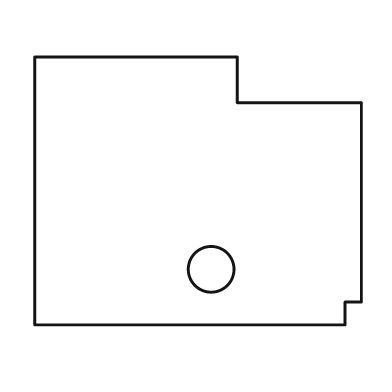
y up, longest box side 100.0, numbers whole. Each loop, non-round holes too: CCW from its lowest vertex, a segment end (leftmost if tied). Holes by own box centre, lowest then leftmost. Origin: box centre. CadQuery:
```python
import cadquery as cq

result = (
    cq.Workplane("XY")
    .moveTo(-50.0, -41.0)
    .lineTo(45.0, -41.0)
    .lineTo(45.0, -34.0)
    .lineTo(50.0, -34.0)
    .lineTo(50.0, 27.0)
    .lineTo(12.0, 27.0)
    .lineTo(12.0, 41.0)
    .lineTo(-50.0, 41.0)
    .close()
    .moveTo(4.0, -24.0)
    .circle(7.0)
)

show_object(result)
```